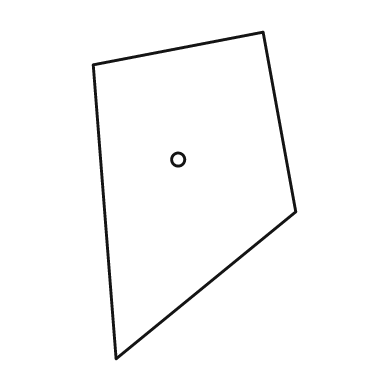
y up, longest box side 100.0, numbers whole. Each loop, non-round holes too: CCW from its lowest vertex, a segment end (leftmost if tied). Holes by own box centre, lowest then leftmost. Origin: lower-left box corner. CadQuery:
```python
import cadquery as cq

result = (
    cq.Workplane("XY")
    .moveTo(7.0, 0.0)
    .lineTo(62.0, 45.0)
    .lineTo(52.0, 100.0)
    .lineTo(0.0, 90.0)
    .close()
    .moveTo(26.0, 61.0)
    .circle(2.0)
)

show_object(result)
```